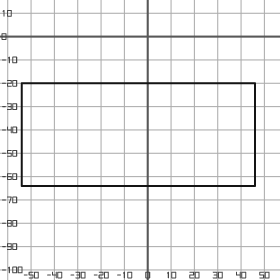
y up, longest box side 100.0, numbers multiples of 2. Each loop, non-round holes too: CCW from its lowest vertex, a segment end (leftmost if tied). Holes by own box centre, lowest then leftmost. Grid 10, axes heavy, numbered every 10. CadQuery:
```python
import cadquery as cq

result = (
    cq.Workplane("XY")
    .moveTo(-54.0, -64.0)
    .lineTo(46.0, -64.0)
    .lineTo(46.0, -20.0)
    .lineTo(-54.0, -20.0)
    .close()
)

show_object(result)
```